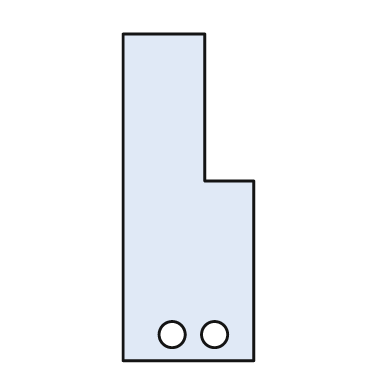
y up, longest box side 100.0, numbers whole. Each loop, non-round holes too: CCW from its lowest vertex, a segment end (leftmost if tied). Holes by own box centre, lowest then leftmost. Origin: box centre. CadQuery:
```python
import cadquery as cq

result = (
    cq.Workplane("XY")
    .moveTo(-20.0, -50.0)
    .lineTo(20.0, -50.0)
    .lineTo(20.0, 5.0)
    .lineTo(5.0, 5.0)
    .lineTo(5.0, 50.0)
    .lineTo(-20.0, 50.0)
    .close()
    .moveTo(-5.0, -42.0)
    .circle(4.0)
    .moveTo(8.0, -42.0)
    .circle(4.0)
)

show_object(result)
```